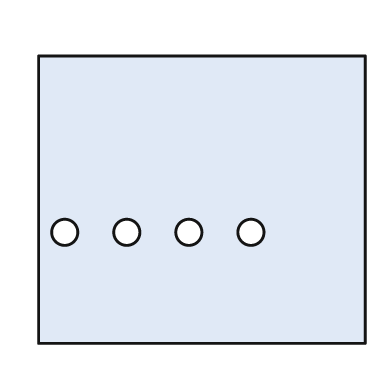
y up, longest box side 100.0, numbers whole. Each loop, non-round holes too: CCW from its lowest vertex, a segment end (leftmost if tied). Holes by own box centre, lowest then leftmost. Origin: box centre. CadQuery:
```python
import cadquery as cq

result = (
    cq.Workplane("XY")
    .moveTo(-50.0, -44.0)
    .lineTo(50.0, -44.0)
    .lineTo(50.0, 44.0)
    .lineTo(-50.0, 44.0)
    .close()
    .moveTo(-42.0, -10.0)
    .circle(4.0)
    .moveTo(-23.0, -10.0)
    .circle(4.0)
    .moveTo(-4.0, -10.0)
    .circle(4.0)
    .moveTo(15.0, -10.0)
    .circle(4.0)
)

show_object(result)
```